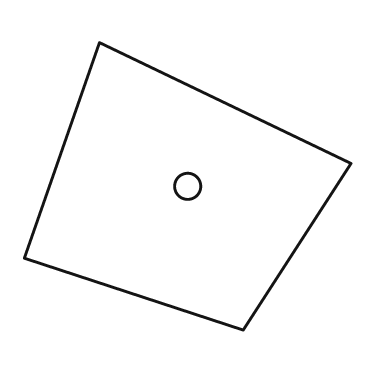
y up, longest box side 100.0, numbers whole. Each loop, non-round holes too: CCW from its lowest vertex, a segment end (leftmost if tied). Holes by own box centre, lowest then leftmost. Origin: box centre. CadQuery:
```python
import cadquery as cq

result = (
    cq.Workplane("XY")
    .moveTo(17.0, -44.0)
    .lineTo(50.0, 7.0)
    .lineTo(-27.0, 44.0)
    .lineTo(-50.0, -22.0)
    .close()
    .moveTo(0.0, 0.0)
    .circle(4.0)
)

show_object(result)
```